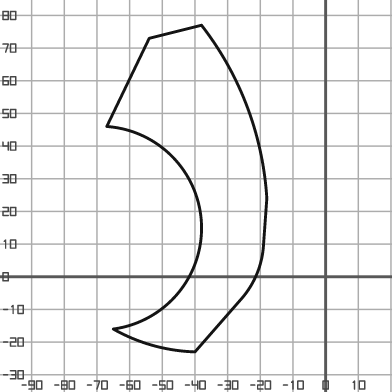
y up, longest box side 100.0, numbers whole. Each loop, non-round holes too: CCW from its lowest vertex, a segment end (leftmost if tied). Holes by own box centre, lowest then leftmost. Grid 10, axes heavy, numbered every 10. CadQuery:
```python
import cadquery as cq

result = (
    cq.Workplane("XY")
    .moveTo(-40.0, -23.0)
    .lineTo(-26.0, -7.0)
    .threePointArc((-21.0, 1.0), (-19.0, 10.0))
    .lineTo(-18.0, 24.0)
    .threePointArc((-24.0, 52.0), (-38.0, 77.0))
    .lineTo(-54.0, 73.0)
    .lineTo(-67.0, 46.0)
    .threePointArc((-38.0, 16.0), (-65.0, -16.0))
    .threePointArc((-53.0, -21.0), (-40.0, -23.0))
    .close()
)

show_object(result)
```